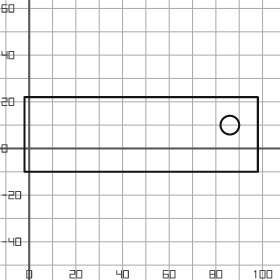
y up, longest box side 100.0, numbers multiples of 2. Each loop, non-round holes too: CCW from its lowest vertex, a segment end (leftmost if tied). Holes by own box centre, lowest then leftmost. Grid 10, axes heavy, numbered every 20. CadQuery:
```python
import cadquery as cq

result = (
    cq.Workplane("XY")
    .moveTo(-2.0, -10.0)
    .lineTo(98.0, -10.0)
    .lineTo(98.0, 22.0)
    .lineTo(-2.0, 22.0)
    .close()
    .moveTo(86.0, 10.0)
    .circle(4.0)
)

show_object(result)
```